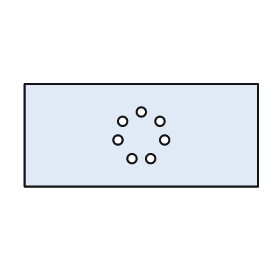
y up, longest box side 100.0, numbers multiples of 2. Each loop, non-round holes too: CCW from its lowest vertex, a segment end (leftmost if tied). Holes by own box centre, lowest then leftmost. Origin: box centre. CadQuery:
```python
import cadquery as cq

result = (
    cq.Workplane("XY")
    .moveTo(-50.0, -22.0)
    .lineTo(50.0, -22.0)
    .lineTo(50.0, 22.0)
    .lineTo(-50.0, 22.0)
    .close()
    .moveTo(-4.0, -10.0)
    .circle(2.0)
    .moveTo(4.0, -10.0)
    .circle(2.0)
    .moveTo(-10.0, -2.0)
    .circle(2.0)
    .moveTo(10.0, -2.0)
    .circle(2.0)
    .moveTo(-8.0, 6.0)
    .circle(2.0)
    .moveTo(8.0, 6.0)
    .circle(2.0)
    .moveTo(0.0, 10.0)
    .circle(2.0)
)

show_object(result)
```